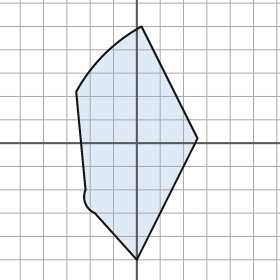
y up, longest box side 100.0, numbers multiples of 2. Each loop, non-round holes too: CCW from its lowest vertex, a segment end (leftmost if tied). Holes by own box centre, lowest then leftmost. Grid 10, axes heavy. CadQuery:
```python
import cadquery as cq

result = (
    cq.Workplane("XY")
    .moveTo(0.0, -50.0)
    .lineTo(26.0, 2.0)
    .lineTo(2.0, 50.0)
    .threePointArc((-14.0, 38.0), (-26.0, 22.0))
    .lineTo(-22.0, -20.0)
    .threePointArc((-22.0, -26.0), (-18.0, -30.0))
    .close()
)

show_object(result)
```